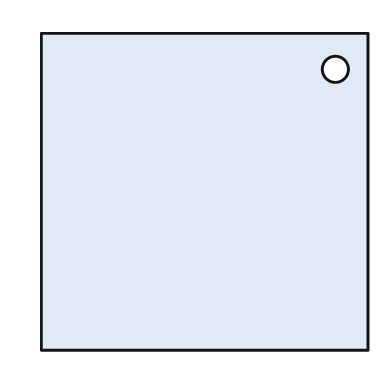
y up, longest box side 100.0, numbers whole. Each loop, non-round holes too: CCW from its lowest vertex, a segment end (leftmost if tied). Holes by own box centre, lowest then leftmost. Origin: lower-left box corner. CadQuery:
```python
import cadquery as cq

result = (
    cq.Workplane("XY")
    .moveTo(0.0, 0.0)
    .lineTo(100.0, 0.0)
    .lineTo(100.0, 97.0)
    .lineTo(0.0, 97.0)
    .close()
    .moveTo(90.0, 86.0)
    .circle(4.0)
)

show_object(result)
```